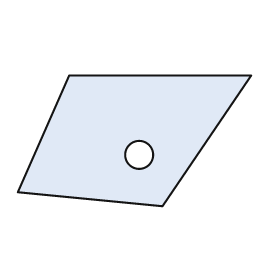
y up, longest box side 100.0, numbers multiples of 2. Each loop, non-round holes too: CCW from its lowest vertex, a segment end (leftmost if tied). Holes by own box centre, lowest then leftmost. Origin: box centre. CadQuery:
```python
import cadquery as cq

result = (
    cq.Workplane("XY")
    .moveTo(12.0, -28.0)
    .lineTo(50.0, 28.0)
    .lineTo(-28.0, 28.0)
    .lineTo(-50.0, -22.0)
    .close()
    .moveTo(2.0, -6.0)
    .circle(6.0)
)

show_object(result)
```